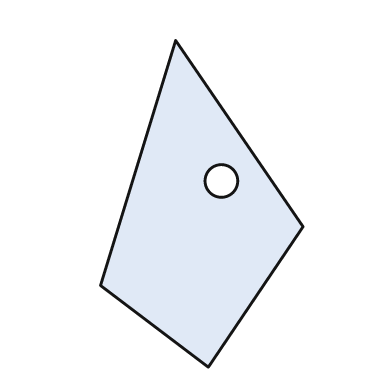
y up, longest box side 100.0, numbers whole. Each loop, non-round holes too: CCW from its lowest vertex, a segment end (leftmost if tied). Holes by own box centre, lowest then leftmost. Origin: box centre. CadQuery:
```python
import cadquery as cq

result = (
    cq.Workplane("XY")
    .moveTo(2.0, -50.0)
    .lineTo(31.0, -7.0)
    .lineTo(-8.0, 50.0)
    .lineTo(-31.0, -25.0)
    .close()
    .moveTo(6.0, 7.0)
    .circle(5.0)
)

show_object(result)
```